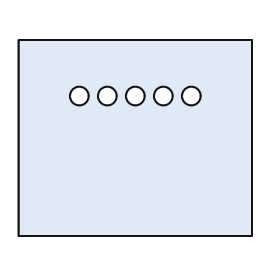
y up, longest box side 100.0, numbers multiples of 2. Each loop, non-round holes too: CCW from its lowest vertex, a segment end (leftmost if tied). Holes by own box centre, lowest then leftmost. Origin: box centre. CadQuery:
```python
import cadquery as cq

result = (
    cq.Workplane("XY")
    .moveTo(-50.0, -42.0)
    .lineTo(50.0, -42.0)
    .lineTo(50.0, 42.0)
    .lineTo(-50.0, 42.0)
    .close()
    .moveTo(-24.0, 18.0)
    .circle(4.0)
    .moveTo(-12.0, 18.0)
    .circle(4.0)
    .moveTo(0.0, 18.0)
    .circle(4.0)
    .moveTo(12.0, 18.0)
    .circle(4.0)
    .moveTo(24.0, 18.0)
    .circle(4.0)
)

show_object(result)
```